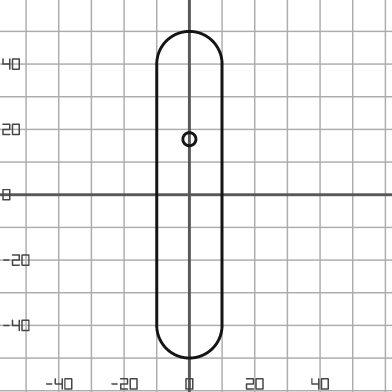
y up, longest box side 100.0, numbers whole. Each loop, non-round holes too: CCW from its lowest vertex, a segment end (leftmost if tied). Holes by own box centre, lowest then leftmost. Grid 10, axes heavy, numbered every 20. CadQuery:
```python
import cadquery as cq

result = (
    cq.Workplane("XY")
    .moveTo(-10.0, -40.0)
    .threePointArc((0.0, -50.0), (10.0, -40.0))
    .lineTo(10.0, 40.0)
    .threePointArc((0.0, 50.0), (-10.0, 40.0))
    .close()
    .moveTo(0.0, 17.0)
    .circle(2.0)
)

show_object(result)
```